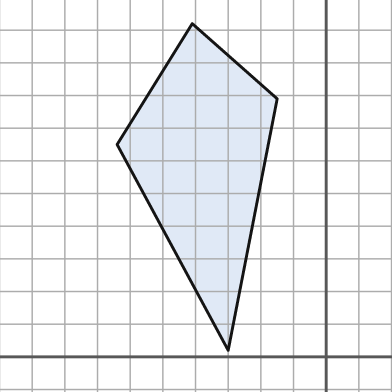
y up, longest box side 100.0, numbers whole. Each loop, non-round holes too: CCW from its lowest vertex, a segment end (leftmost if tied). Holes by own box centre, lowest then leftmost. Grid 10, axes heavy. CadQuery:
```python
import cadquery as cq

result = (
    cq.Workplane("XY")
    .moveTo(-30.0, 2.0)
    .lineTo(-15.0, 79.0)
    .lineTo(-41.0, 102.0)
    .lineTo(-64.0, 65.0)
    .close()
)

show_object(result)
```